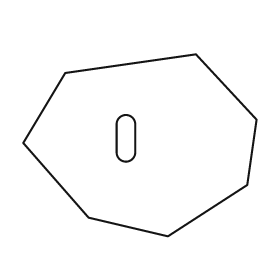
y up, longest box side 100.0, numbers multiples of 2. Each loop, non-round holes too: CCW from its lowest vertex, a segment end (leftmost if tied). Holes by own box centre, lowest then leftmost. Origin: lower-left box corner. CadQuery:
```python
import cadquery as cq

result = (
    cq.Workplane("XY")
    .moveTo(62.0, 0.0)
    .lineTo(96.0, 22.0)
    .lineTo(100.0, 50.0)
    .lineTo(74.0, 78.0)
    .lineTo(18.0, 70.0)
    .lineTo(0.0, 40.0)
    .lineTo(28.0, 8.0)
    .close()
    .moveTo(40.0, 36.0)
    .threePointArc((44.0, 32.0), (48.0, 36.0))
    .lineTo(48.0, 48.0)
    .threePointArc((44.0, 52.0), (40.0, 48.0))
    .close()
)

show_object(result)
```